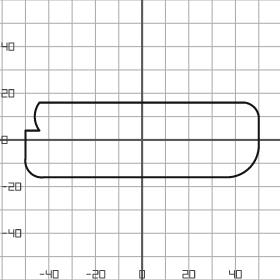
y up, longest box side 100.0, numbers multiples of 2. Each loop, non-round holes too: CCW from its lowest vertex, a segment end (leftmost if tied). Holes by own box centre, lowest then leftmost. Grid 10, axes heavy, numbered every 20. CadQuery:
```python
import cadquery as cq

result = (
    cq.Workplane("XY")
    .moveTo(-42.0, -16.0)
    .lineTo(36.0, -16.0)
    .threePointArc((46.0, -12.0), (50.0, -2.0))
    .lineTo(50.0, 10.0)
    .threePointArc((48.0, 14.0), (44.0, 16.0))
    .lineTo(-44.0, 16.0)
    .threePointArc((-46.0, 10.0), (-44.0, 4.0))
    .lineTo(-50.0, 4.0)
    .lineTo(-50.0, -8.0)
    .threePointArc((-48.0, -14.0), (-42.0, -16.0))
    .close()
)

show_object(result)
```